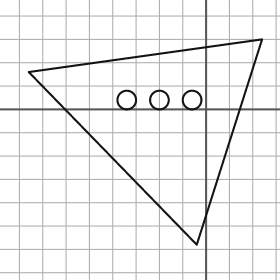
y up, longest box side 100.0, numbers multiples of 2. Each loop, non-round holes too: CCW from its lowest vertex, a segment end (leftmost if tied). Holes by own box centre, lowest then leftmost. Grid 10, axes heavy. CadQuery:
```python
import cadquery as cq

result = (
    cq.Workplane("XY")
    .moveTo(-4.0, -58.0)
    .lineTo(24.0, 30.0)
    .lineTo(-76.0, 16.0)
    .close()
    .moveTo(-34.0, 4.0)
    .circle(4.0)
    .moveTo(-20.0, 4.0)
    .circle(4.0)
    .moveTo(-6.0, 4.0)
    .circle(4.0)
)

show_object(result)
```